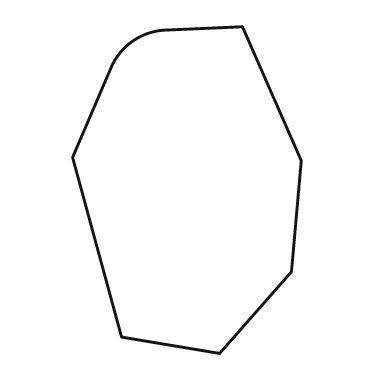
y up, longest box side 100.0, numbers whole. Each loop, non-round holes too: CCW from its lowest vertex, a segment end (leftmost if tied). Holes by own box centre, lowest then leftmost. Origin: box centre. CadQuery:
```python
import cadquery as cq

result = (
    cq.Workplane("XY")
    .moveTo(10.0, -50.0)
    .lineTo(32.0, -25.0)
    .lineTo(35.0, 9.0)
    .lineTo(17.0, 50.0)
    .lineTo(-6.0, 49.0)
    .threePointArc((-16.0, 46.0), (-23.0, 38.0))
    .lineTo(-35.0, 10.0)
    .lineTo(-20.0, -45.0)
    .close()
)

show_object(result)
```